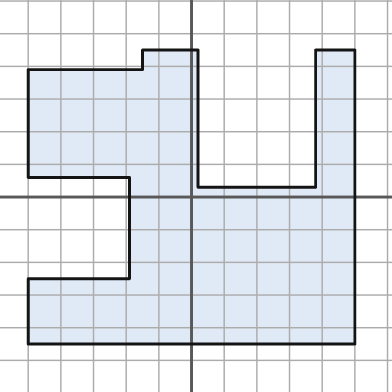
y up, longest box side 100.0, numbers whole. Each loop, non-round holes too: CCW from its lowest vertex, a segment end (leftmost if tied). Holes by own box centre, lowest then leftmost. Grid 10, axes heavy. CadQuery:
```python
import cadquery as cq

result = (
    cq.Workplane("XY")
    .moveTo(-50.0, -45.0)
    .lineTo(50.0, -45.0)
    .lineTo(50.0, 45.0)
    .lineTo(38.0, 45.0)
    .lineTo(38.0, 3.0)
    .lineTo(2.0, 3.0)
    .lineTo(2.0, 45.0)
    .lineTo(-15.0, 45.0)
    .lineTo(-15.0, 39.0)
    .lineTo(-50.0, 39.0)
    .lineTo(-50.0, 6.0)
    .lineTo(-19.0, 6.0)
    .lineTo(-19.0, -25.0)
    .lineTo(-50.0, -25.0)
    .close()
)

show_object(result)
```